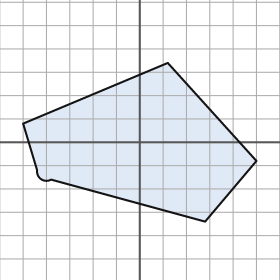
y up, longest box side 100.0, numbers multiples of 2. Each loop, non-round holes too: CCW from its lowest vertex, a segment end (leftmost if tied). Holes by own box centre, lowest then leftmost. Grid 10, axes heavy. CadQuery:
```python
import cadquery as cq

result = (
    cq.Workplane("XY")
    .moveTo(28.0, -34.0)
    .lineTo(50.0, -8.0)
    .lineTo(12.0, 34.0)
    .lineTo(-50.0, 8.0)
    .lineTo(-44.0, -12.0)
    .threePointArc((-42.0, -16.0), (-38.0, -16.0))
    .close()
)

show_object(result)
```